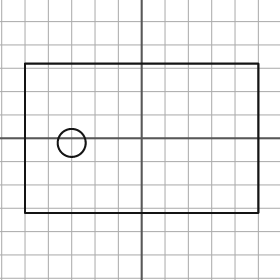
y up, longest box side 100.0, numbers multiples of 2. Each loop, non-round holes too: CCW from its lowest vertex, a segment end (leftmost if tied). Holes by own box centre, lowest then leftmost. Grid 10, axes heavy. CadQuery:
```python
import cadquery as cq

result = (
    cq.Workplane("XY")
    .moveTo(-50.0, -32.0)
    .lineTo(50.0, -32.0)
    .lineTo(50.0, 32.0)
    .lineTo(-50.0, 32.0)
    .close()
    .moveTo(-30.0, -2.0)
    .circle(6.0)
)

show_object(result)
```